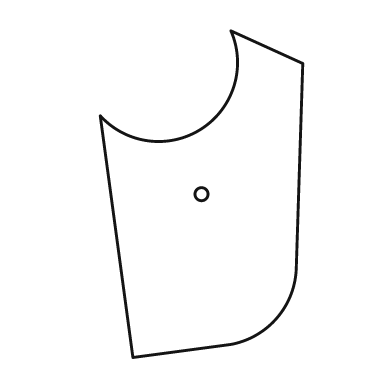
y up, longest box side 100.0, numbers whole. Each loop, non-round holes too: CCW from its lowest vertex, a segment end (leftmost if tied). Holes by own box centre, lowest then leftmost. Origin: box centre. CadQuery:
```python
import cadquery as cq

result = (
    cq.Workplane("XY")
    .moveTo(-21.0, -50.0)
    .lineTo(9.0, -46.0)
    .threePointArc((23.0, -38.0), (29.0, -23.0))
    .lineTo(31.0, 40.0)
    .lineTo(9.0, 50.0)
    .threePointArc((0.0, 20.0), (-31.0, 24.0))
    .close()
    .moveTo(0.0, 0.0)
    .circle(2.0)
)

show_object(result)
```